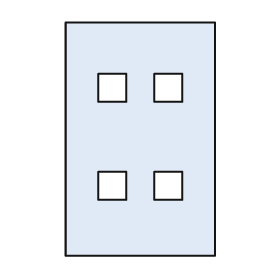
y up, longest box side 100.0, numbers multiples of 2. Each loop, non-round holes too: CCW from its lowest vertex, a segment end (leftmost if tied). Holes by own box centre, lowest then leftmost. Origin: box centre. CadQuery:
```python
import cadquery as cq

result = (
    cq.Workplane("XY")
    .moveTo(-32.0, -50.0)
    .lineTo(32.0, -50.0)
    .lineTo(32.0, 50.0)
    .lineTo(-32.0, 50.0)
    .close()
    .moveTo(-18.0, -26.0)
    .lineTo(-6.0, -26.0)
    .lineTo(-6.0, -14.0)
    .lineTo(-18.0, -14.0)
    .close()
    .moveTo(6.0, -26.0)
    .lineTo(18.0, -26.0)
    .lineTo(18.0, -14.0)
    .lineTo(6.0, -14.0)
    .close()
    .moveTo(-18.0, 16.0)
    .lineTo(-6.0, 16.0)
    .lineTo(-6.0, 28.0)
    .lineTo(-18.0, 28.0)
    .close()
    .moveTo(6.0, 16.0)
    .lineTo(18.0, 16.0)
    .lineTo(18.0, 28.0)
    .lineTo(6.0, 28.0)
    .close()
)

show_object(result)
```